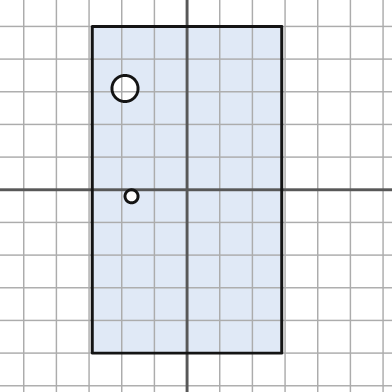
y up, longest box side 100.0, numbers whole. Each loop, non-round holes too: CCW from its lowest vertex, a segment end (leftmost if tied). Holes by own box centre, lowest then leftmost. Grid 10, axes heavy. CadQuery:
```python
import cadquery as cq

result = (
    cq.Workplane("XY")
    .moveTo(-29.0, -50.0)
    .lineTo(29.0, -50.0)
    .lineTo(29.0, 50.0)
    .lineTo(-29.0, 50.0)
    .close()
    .moveTo(-17.0, -2.0)
    .circle(2.0)
    .moveTo(-19.0, 31.0)
    .circle(4.0)
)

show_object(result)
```